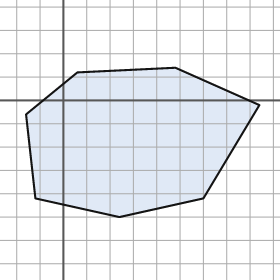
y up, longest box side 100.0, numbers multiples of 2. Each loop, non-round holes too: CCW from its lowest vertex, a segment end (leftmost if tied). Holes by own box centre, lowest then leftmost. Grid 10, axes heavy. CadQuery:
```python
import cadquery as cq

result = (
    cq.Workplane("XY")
    .moveTo(24.0, -50.0)
    .lineTo(60.0, -42.0)
    .lineTo(84.0, -2.0)
    .lineTo(48.0, 14.0)
    .lineTo(6.0, 12.0)
    .lineTo(-16.0, -6.0)
    .lineTo(-12.0, -42.0)
    .close()
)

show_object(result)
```